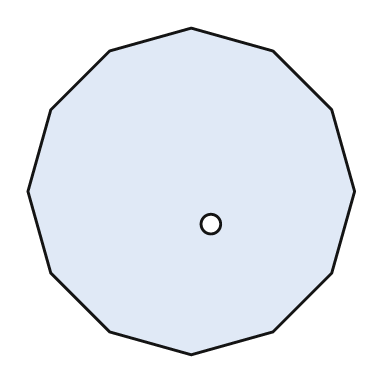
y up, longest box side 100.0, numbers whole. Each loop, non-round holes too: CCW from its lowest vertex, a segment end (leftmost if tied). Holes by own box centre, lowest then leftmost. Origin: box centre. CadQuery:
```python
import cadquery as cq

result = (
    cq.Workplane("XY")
    .moveTo(0.0, -50.0)
    .lineTo(25.0, -43.0)
    .lineTo(43.0, -25.0)
    .lineTo(50.0, 0.0)
    .lineTo(43.0, 25.0)
    .lineTo(25.0, 43.0)
    .lineTo(0.0, 50.0)
    .lineTo(-25.0, 43.0)
    .lineTo(-43.0, 25.0)
    .lineTo(-50.0, 0.0)
    .lineTo(-43.0, -25.0)
    .lineTo(-25.0, -43.0)
    .close()
    .moveTo(6.0, -10.0)
    .circle(3.0)
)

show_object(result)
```